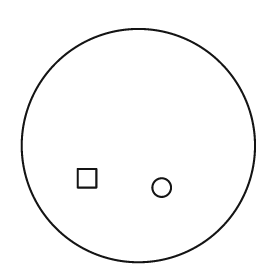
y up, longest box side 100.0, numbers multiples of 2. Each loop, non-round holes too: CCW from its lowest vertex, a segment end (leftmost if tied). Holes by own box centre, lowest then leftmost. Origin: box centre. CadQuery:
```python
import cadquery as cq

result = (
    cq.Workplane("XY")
    .moveTo(0.0, 0.0)
    .circle(50.0)
    .moveTo(10.0, -18.0)
    .circle(4.0)
    .moveTo(-26.0, -18.0)
    .lineTo(-18.0, -18.0)
    .lineTo(-18.0, -10.0)
    .lineTo(-26.0, -10.0)
    .close()
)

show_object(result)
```